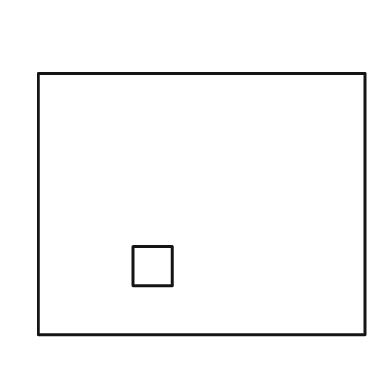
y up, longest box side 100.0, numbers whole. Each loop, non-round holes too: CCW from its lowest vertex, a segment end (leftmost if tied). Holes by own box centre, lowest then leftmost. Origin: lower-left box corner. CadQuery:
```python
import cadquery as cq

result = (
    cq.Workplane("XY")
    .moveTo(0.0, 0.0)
    .lineTo(100.0, 0.0)
    .lineTo(100.0, 80.0)
    .lineTo(0.0, 80.0)
    .close()
    .moveTo(29.0, 15.0)
    .lineTo(41.0, 15.0)
    .lineTo(41.0, 27.0)
    .lineTo(29.0, 27.0)
    .close()
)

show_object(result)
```